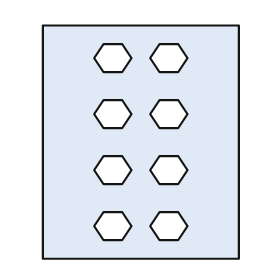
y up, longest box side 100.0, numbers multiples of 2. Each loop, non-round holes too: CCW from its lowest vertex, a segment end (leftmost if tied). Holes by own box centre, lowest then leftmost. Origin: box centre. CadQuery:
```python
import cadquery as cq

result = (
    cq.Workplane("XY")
    .moveTo(-42.0, -50.0)
    .lineTo(42.0, -50.0)
    .lineTo(42.0, 50.0)
    .lineTo(-42.0, 50.0)
    .close()
    .moveTo(-16.0, -42.0)
    .lineTo(-8.0, -42.0)
    .lineTo(-4.0, -36.0)
    .lineTo(-8.0, -30.0)
    .lineTo(-16.0, -30.0)
    .lineTo(-20.0, -36.0)
    .close()
    .moveTo(8.0, -42.0)
    .lineTo(16.0, -42.0)
    .lineTo(20.0, -36.0)
    .lineTo(16.0, -30.0)
    .lineTo(8.0, -30.0)
    .lineTo(4.0, -36.0)
    .close()
    .moveTo(-16.0, -18.0)
    .lineTo(-8.0, -18.0)
    .lineTo(-4.0, -12.0)
    .lineTo(-8.0, -6.0)
    .lineTo(-16.0, -6.0)
    .lineTo(-20.0, -12.0)
    .close()
    .moveTo(8.0, -18.0)
    .lineTo(16.0, -18.0)
    .lineTo(20.0, -12.0)
    .lineTo(16.0, -6.0)
    .lineTo(8.0, -6.0)
    .lineTo(4.0, -12.0)
    .close()
    .moveTo(-16.0, 6.0)
    .lineTo(-8.0, 6.0)
    .lineTo(-4.0, 12.0)
    .lineTo(-8.0, 18.0)
    .lineTo(-16.0, 18.0)
    .lineTo(-20.0, 12.0)
    .close()
    .moveTo(8.0, 6.0)
    .lineTo(16.0, 6.0)
    .lineTo(20.0, 12.0)
    .lineTo(16.0, 18.0)
    .lineTo(8.0, 18.0)
    .lineTo(4.0, 12.0)
    .close()
    .moveTo(-16.0, 30.0)
    .lineTo(-8.0, 30.0)
    .lineTo(-4.0, 36.0)
    .lineTo(-8.0, 42.0)
    .lineTo(-16.0, 42.0)
    .lineTo(-20.0, 36.0)
    .close()
    .moveTo(8.0, 30.0)
    .lineTo(16.0, 30.0)
    .lineTo(20.0, 36.0)
    .lineTo(16.0, 42.0)
    .lineTo(8.0, 42.0)
    .lineTo(4.0, 36.0)
    .close()
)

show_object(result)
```